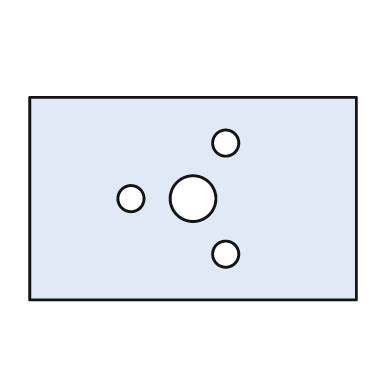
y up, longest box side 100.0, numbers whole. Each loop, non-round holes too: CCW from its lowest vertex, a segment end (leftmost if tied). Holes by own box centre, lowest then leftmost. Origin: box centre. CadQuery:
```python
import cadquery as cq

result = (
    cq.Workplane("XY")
    .moveTo(-50.0, -31.0)
    .lineTo(50.0, -31.0)
    .lineTo(50.0, 31.0)
    .lineTo(-50.0, 31.0)
    .close()
    .moveTo(10.0, -17.0)
    .circle(4.0)
    .moveTo(-19.0, 0.0)
    .circle(4.0)
    .moveTo(0.0, 0.0)
    .circle(7.0)
    .moveTo(10.0, 17.0)
    .circle(4.0)
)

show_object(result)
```